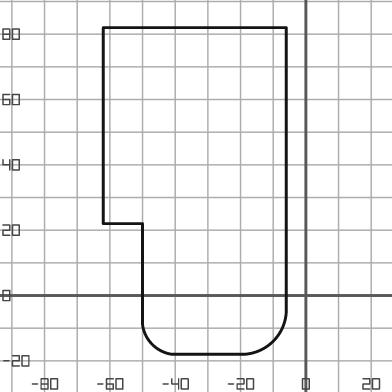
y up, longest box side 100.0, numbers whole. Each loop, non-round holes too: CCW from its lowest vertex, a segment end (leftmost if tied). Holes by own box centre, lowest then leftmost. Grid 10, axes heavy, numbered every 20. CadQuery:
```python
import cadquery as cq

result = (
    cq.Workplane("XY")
    .moveTo(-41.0, -18.0)
    .lineTo(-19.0, -18.0)
    .threePointArc((-10.0, -14.0), (-6.0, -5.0))
    .lineTo(-6.0, 82.0)
    .lineTo(-62.0, 82.0)
    .lineTo(-62.0, 22.0)
    .lineTo(-50.0, 22.0)
    .lineTo(-50.0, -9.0)
    .threePointArc((-47.0, -15.0), (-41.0, -18.0))
    .close()
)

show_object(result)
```